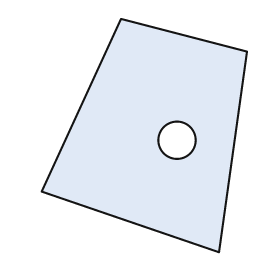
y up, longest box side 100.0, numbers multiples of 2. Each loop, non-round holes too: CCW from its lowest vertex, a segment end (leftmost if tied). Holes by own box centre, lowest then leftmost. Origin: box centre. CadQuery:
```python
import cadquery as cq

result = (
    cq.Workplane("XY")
    .moveTo(32.0, -50.0)
    .lineTo(44.0, 36.0)
    .lineTo(-10.0, 50.0)
    .lineTo(-44.0, -24.0)
    .close()
    .moveTo(14.0, -2.0)
    .circle(8.0)
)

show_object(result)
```